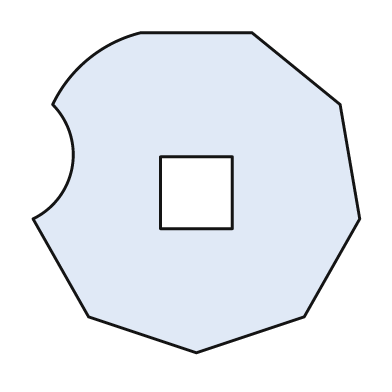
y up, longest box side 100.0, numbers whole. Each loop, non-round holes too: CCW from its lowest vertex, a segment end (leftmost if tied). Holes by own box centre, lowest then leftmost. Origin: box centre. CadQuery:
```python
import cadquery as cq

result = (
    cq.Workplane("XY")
    .moveTo(0.0, -49.0)
    .lineTo(33.0, -38.0)
    .lineTo(50.0, -8.0)
    .lineTo(44.0, 27.0)
    .lineTo(17.0, 49.0)
    .lineTo(-17.0, 49.0)
    .threePointArc((-33.0, 41.0), (-44.0, 27.0))
    .threePointArc((-38.0, 8.0), (-50.0, -8.0))
    .lineTo(-33.0, -38.0)
    .close()
    .moveTo(-11.0, -11.0)
    .lineTo(11.0, -11.0)
    .lineTo(11.0, 11.0)
    .lineTo(-11.0, 11.0)
    .close()
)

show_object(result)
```